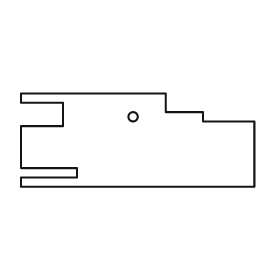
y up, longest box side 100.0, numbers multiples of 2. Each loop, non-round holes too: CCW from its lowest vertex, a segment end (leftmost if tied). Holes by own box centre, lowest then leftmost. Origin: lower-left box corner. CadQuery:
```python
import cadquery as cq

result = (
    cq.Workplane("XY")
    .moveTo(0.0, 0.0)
    .lineTo(100.0, 0.0)
    .lineTo(100.0, 28.0)
    .lineTo(78.0, 28.0)
    .lineTo(78.0, 32.0)
    .lineTo(62.0, 32.0)
    .lineTo(62.0, 40.0)
    .lineTo(0.0, 40.0)
    .lineTo(0.0, 36.0)
    .lineTo(18.0, 36.0)
    .lineTo(18.0, 26.0)
    .lineTo(0.0, 26.0)
    .lineTo(0.0, 8.0)
    .lineTo(24.0, 8.0)
    .lineTo(24.0, 4.0)
    .lineTo(0.0, 4.0)
    .close()
    .moveTo(48.0, 30.0)
    .circle(2.0)
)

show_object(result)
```